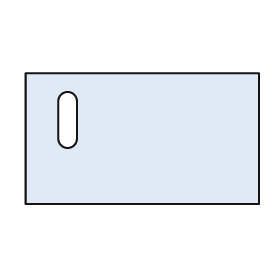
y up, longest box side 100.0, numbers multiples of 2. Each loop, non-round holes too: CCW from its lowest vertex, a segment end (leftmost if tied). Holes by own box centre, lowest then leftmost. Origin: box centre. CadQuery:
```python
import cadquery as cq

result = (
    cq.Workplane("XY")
    .moveTo(-50.0, -28.0)
    .lineTo(50.0, -28.0)
    .lineTo(50.0, 28.0)
    .lineTo(-50.0, 28.0)
    .close()
    .moveTo(-36.0, 0.0)
    .threePointArc((-32.0, -4.0), (-28.0, 0.0))
    .lineTo(-28.0, 16.0)
    .threePointArc((-32.0, 20.0), (-36.0, 16.0))
    .close()
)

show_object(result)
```